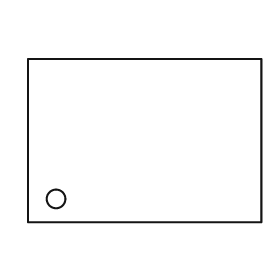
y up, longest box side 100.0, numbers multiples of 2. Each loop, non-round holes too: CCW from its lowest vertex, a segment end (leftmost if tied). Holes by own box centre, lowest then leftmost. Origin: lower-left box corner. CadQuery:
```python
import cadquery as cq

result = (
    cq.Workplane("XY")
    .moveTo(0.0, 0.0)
    .lineTo(100.0, 0.0)
    .lineTo(100.0, 70.0)
    .lineTo(0.0, 70.0)
    .close()
    .moveTo(12.0, 10.0)
    .circle(4.0)
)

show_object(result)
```